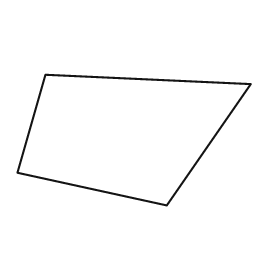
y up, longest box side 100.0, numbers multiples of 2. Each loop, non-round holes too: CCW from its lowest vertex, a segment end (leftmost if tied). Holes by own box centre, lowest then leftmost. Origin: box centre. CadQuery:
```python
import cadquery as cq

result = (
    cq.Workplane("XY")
    .moveTo(14.0, -28.0)
    .lineTo(50.0, 24.0)
    .lineTo(-38.0, 28.0)
    .lineTo(-50.0, -14.0)
    .close()
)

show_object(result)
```